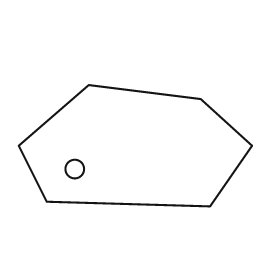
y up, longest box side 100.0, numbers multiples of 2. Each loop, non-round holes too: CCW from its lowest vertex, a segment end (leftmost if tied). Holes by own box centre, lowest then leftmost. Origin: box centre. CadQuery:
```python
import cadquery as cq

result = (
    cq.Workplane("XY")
    .moveTo(32.0, -26.0)
    .lineTo(50.0, 0.0)
    .lineTo(28.0, 20.0)
    .lineTo(-20.0, 26.0)
    .lineTo(-50.0, 0.0)
    .lineTo(-38.0, -24.0)
    .close()
    .moveTo(-26.0, -10.0)
    .circle(4.0)
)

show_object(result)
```